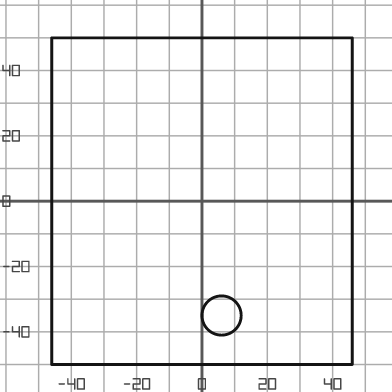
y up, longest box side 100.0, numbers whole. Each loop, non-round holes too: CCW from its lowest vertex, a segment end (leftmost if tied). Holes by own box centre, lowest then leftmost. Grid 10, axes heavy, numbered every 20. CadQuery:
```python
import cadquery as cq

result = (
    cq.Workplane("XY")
    .moveTo(-46.0, -50.0)
    .lineTo(46.0, -50.0)
    .lineTo(46.0, 50.0)
    .lineTo(-46.0, 50.0)
    .close()
    .moveTo(6.0, -35.0)
    .circle(6.0)
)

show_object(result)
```